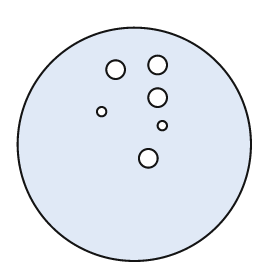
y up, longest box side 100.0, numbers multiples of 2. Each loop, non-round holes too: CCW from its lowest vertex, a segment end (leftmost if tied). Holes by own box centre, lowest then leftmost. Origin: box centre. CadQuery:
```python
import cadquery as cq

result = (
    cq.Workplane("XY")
    .moveTo(0.0, 0.0)
    .circle(50.0)
    .moveTo(6.0, -6.0)
    .circle(4.0)
    .moveTo(12.0, 8.0)
    .circle(2.0)
    .moveTo(-14.0, 14.0)
    .circle(2.0)
    .moveTo(10.0, 20.0)
    .circle(4.0)
    .moveTo(-8.0, 32.0)
    .circle(4.0)
    .moveTo(10.0, 34.0)
    .circle(4.0)
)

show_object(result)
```